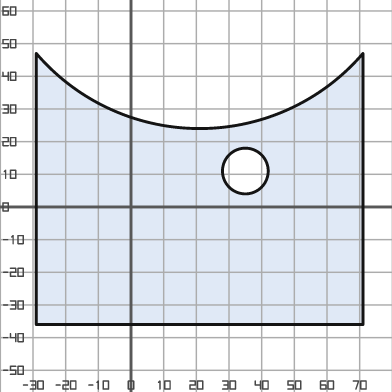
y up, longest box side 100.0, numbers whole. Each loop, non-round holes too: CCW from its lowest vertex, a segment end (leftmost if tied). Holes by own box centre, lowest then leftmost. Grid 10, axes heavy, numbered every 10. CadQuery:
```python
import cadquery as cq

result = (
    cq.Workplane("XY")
    .moveTo(-29.0, -36.0)
    .lineTo(71.0, -36.0)
    .lineTo(71.0, 47.0)
    .threePointArc((21.0, 24.0), (-29.0, 47.0))
    .close()
    .moveTo(35.0, 11.0)
    .circle(7.0)
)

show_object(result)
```